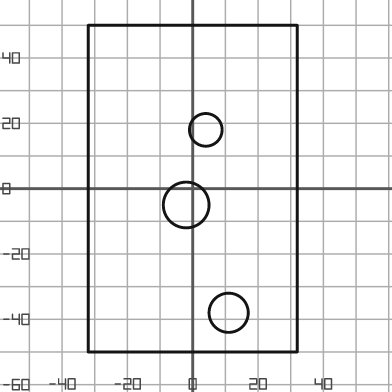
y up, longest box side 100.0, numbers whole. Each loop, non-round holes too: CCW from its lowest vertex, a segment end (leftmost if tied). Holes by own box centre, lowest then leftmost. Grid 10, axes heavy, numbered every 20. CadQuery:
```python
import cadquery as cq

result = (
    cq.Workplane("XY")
    .moveTo(-32.0, -50.0)
    .lineTo(32.0, -50.0)
    .lineTo(32.0, 50.0)
    .lineTo(-32.0, 50.0)
    .close()
    .moveTo(11.0, -38.0)
    .circle(6.0)
    .moveTo(-2.0, -5.0)
    .circle(7.0)
    .moveTo(4.0, 18.0)
    .circle(5.0)
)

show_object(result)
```